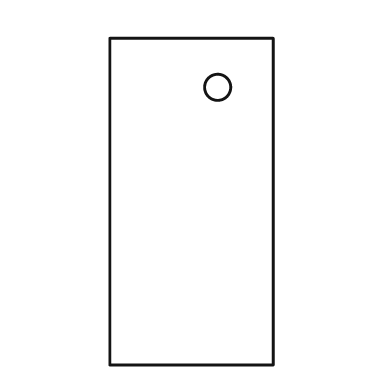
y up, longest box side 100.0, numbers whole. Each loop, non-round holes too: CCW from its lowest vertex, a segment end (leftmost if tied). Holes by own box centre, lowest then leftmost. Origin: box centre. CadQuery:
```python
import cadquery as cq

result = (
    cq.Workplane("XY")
    .moveTo(-25.0, -50.0)
    .lineTo(25.0, -50.0)
    .lineTo(25.0, 50.0)
    .lineTo(-25.0, 50.0)
    .close()
    .moveTo(8.0, 35.0)
    .circle(4.0)
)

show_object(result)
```